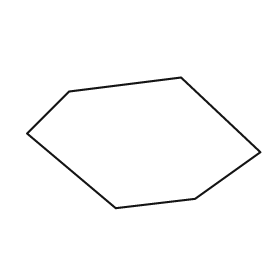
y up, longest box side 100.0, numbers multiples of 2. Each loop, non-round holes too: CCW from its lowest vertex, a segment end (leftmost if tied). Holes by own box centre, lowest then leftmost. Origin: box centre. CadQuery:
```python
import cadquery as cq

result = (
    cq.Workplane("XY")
    .moveTo(-12.0, -28.0)
    .lineTo(22.0, -24.0)
    .lineTo(50.0, -4.0)
    .lineTo(16.0, 28.0)
    .lineTo(-32.0, 22.0)
    .lineTo(-50.0, 4.0)
    .close()
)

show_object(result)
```